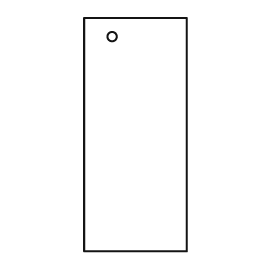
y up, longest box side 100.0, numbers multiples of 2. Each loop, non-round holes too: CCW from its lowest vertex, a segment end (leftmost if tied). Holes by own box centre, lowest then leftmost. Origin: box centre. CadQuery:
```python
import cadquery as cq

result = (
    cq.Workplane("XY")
    .moveTo(-22.0, -50.0)
    .lineTo(22.0, -50.0)
    .lineTo(22.0, 50.0)
    .lineTo(-22.0, 50.0)
    .close()
    .moveTo(-10.0, 42.0)
    .circle(2.0)
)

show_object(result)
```